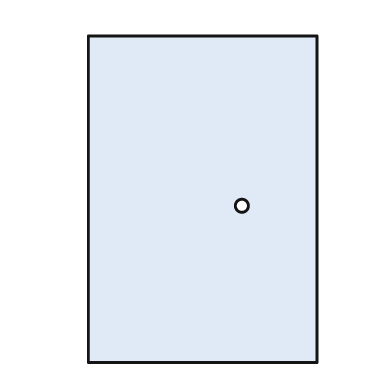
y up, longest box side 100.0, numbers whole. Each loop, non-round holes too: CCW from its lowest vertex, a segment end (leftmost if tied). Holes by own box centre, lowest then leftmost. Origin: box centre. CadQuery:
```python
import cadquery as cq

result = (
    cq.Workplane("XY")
    .moveTo(-35.0, -50.0)
    .lineTo(35.0, -50.0)
    .lineTo(35.0, 50.0)
    .lineTo(-35.0, 50.0)
    .close()
    .moveTo(12.0, -2.0)
    .circle(2.0)
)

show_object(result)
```